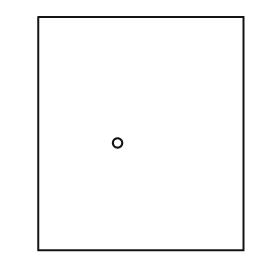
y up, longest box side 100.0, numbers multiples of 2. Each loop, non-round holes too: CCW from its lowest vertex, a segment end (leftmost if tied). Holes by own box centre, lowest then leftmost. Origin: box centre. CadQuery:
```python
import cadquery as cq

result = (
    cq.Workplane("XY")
    .moveTo(-44.0, -50.0)
    .lineTo(44.0, -50.0)
    .lineTo(44.0, 50.0)
    .lineTo(-44.0, 50.0)
    .close()
    .moveTo(-10.0, -4.0)
    .circle(2.0)
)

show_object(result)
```